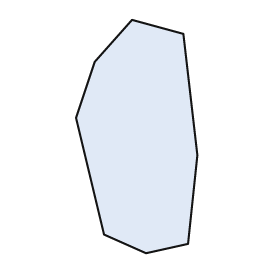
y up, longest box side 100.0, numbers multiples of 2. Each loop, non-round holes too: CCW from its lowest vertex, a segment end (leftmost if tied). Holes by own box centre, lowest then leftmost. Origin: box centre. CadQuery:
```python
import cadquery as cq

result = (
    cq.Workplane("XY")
    .moveTo(4.0, -50.0)
    .lineTo(22.0, -46.0)
    .lineTo(26.0, -8.0)
    .lineTo(20.0, 44.0)
    .lineTo(-2.0, 50.0)
    .lineTo(-18.0, 32.0)
    .lineTo(-26.0, 8.0)
    .lineTo(-14.0, -42.0)
    .close()
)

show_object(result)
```